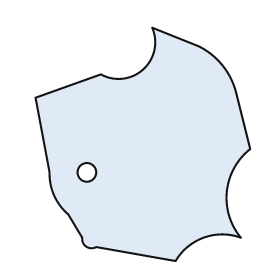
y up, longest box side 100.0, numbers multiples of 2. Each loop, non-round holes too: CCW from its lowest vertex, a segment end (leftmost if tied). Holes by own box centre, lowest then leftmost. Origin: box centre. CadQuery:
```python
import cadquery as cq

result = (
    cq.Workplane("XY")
    .moveTo(14.0, -50.0)
    .threePointArc((26.0, -40.0), (42.0, -40.0))
    .threePointArc((36.0, -20.0), (46.0, -2.0))
    .lineTo(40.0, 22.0)
    .threePointArc((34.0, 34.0), (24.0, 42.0))
    .lineTo(4.0, 50.0)
    .threePointArc((0.0, 32.0), (-18.0, 30.0))
    .lineTo(-46.0, 20.0)
    .lineTo(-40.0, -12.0)
    .threePointArc((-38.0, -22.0), (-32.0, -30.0))
    .lineTo(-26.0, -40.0)
    .threePointArc((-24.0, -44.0), (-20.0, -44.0))
    .close()
    .moveTo(-24.0, -12.0)
    .circle(4.0)
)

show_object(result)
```